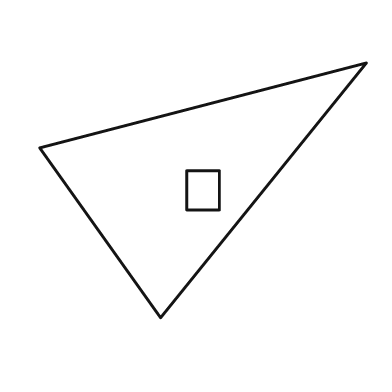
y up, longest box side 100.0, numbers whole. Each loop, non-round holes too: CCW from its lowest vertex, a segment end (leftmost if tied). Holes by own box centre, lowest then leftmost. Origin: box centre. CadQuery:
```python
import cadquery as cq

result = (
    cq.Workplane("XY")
    .moveTo(-13.0, -39.0)
    .lineTo(50.0, 39.0)
    .lineTo(-50.0, 13.0)
    .close()
    .moveTo(-5.0, -6.0)
    .lineTo(5.0, -6.0)
    .lineTo(5.0, 6.0)
    .lineTo(-5.0, 6.0)
    .close()
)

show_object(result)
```